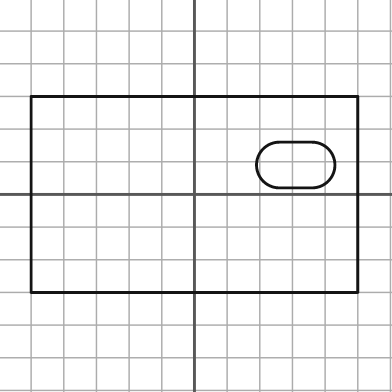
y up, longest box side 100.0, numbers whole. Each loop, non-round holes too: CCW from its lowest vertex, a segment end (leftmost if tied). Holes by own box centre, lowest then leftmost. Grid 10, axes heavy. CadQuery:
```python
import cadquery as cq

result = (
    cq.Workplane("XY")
    .moveTo(-50.0, -30.0)
    .lineTo(50.0, -30.0)
    .lineTo(50.0, 30.0)
    .lineTo(-50.0, 30.0)
    .close()
    .moveTo(26.0, 2.0)
    .lineTo(36.0, 2.0)
    .threePointArc((43.0, 9.0), (36.0, 16.0))
    .lineTo(26.0, 16.0)
    .threePointArc((19.0, 9.0), (26.0, 2.0))
    .close()
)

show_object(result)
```